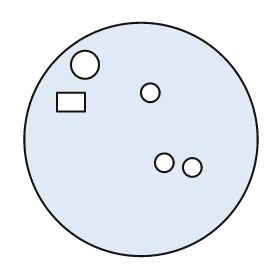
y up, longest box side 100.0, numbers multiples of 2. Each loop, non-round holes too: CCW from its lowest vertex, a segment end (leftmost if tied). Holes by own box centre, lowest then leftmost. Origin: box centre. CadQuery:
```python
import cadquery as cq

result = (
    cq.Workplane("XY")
    .moveTo(0.0, 0.0)
    .circle(50.0)
    .moveTo(22.0, -12.0)
    .circle(4.0)
    .moveTo(10.0, -10.0)
    .circle(4.0)
    .moveTo(-36.0, 12.0)
    .lineTo(-24.0, 12.0)
    .lineTo(-24.0, 20.0)
    .lineTo(-36.0, 20.0)
    .close()
    .moveTo(4.0, 20.0)
    .circle(4.0)
    .moveTo(-24.0, 32.0)
    .circle(6.0)
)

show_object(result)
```